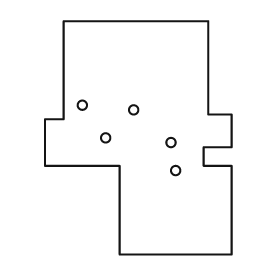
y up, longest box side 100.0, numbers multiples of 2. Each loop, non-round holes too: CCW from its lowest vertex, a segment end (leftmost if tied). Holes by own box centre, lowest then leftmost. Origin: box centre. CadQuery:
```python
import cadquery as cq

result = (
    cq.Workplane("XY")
    .moveTo(-8.0, -50.0)
    .lineTo(40.0, -50.0)
    .lineTo(40.0, -12.0)
    .lineTo(28.0, -12.0)
    .lineTo(28.0, -4.0)
    .lineTo(40.0, -4.0)
    .lineTo(40.0, 10.0)
    .lineTo(30.0, 10.0)
    .lineTo(30.0, 50.0)
    .lineTo(-32.0, 50.0)
    .lineTo(-32.0, 8.0)
    .lineTo(-40.0, 8.0)
    .lineTo(-40.0, -12.0)
    .lineTo(-8.0, -12.0)
    .close()
    .moveTo(16.0, -14.0)
    .circle(2.0)
    .moveTo(14.0, -2.0)
    .circle(2.0)
    .moveTo(-14.0, 0.0)
    .circle(2.0)
    .moveTo(-2.0, 12.0)
    .circle(2.0)
    .moveTo(-24.0, 14.0)
    .circle(2.0)
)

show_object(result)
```